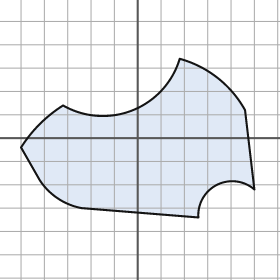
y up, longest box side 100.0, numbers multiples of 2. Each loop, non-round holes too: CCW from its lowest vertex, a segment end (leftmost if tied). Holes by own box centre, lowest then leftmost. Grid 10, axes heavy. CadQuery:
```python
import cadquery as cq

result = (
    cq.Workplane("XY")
    .moveTo(26.0, -34.0)
    .threePointArc((34.0, -20.0), (50.0, -22.0))
    .lineTo(46.0, 12.0)
    .threePointArc((34.0, 26.0), (18.0, 34.0))
    .threePointArc((-2.0, 12.0), (-32.0, 14.0))
    .threePointArc((-42.0, 6.0), (-50.0, -4.0))
    .lineTo(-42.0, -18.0)
    .threePointArc((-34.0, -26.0), (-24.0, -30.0))
    .close()
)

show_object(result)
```